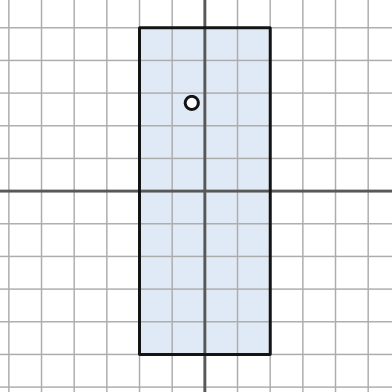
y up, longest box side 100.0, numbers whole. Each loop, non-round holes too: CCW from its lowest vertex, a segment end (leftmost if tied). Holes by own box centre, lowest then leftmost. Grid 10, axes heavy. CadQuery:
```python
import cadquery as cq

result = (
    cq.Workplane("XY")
    .moveTo(-20.0, -50.0)
    .lineTo(20.0, -50.0)
    .lineTo(20.0, 50.0)
    .lineTo(-20.0, 50.0)
    .close()
    .moveTo(-4.0, 27.0)
    .circle(2.0)
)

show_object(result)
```